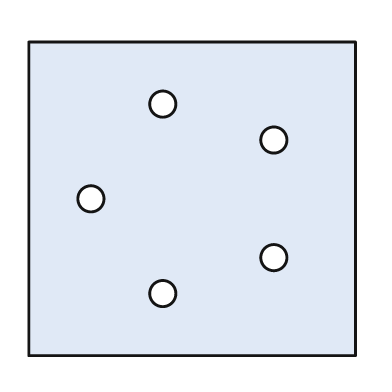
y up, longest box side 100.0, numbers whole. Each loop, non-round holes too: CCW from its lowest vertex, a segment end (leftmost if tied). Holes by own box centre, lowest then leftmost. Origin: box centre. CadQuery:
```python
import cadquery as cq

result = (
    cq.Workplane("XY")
    .moveTo(-50.0, -48.0)
    .lineTo(50.0, -48.0)
    .lineTo(50.0, 48.0)
    .lineTo(-50.0, 48.0)
    .close()
    .moveTo(-9.0, -29.0)
    .circle(4.0)
    .moveTo(25.0, -18.0)
    .circle(4.0)
    .moveTo(-31.0, 0.0)
    .circle(4.0)
    .moveTo(25.0, 18.0)
    .circle(4.0)
    .moveTo(-9.0, 29.0)
    .circle(4.0)
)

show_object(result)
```